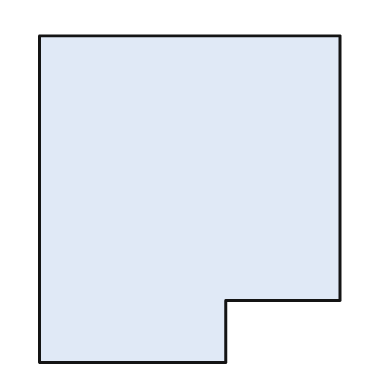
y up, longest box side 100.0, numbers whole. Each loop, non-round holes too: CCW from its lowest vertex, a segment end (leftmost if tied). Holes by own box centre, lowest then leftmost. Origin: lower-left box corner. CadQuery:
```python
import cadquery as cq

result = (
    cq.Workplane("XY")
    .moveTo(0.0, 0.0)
    .lineTo(57.0, 0.0)
    .lineTo(57.0, 19.0)
    .lineTo(92.0, 19.0)
    .lineTo(92.0, 100.0)
    .lineTo(0.0, 100.0)
    .close()
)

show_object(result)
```